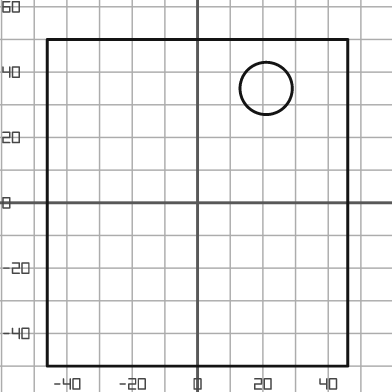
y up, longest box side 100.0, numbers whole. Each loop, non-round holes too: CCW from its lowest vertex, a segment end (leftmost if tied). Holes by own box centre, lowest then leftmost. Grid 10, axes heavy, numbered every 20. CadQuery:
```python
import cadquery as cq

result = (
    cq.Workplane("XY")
    .moveTo(-46.0, -50.0)
    .lineTo(46.0, -50.0)
    .lineTo(46.0, 50.0)
    .lineTo(-46.0, 50.0)
    .close()
    .moveTo(21.0, 35.0)
    .circle(8.0)
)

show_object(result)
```